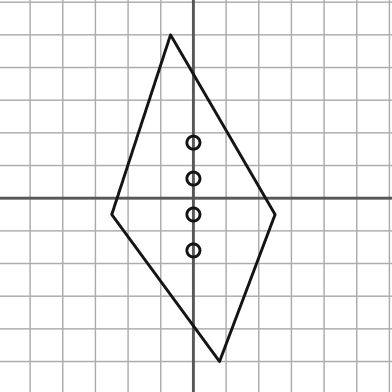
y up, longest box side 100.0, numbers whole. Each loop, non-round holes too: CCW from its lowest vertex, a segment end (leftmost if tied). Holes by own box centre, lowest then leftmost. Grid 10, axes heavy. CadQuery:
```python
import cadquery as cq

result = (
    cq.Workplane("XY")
    .moveTo(8.0, -50.0)
    .lineTo(25.0, -5.0)
    .lineTo(-7.0, 50.0)
    .lineTo(-25.0, -5.0)
    .close()
    .moveTo(0.0, -16.0)
    .circle(2.0)
    .moveTo(0.0, -5.0)
    .circle(2.0)
    .moveTo(0.0, 6.0)
    .circle(2.0)
    .moveTo(0.0, 17.0)
    .circle(2.0)
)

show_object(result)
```